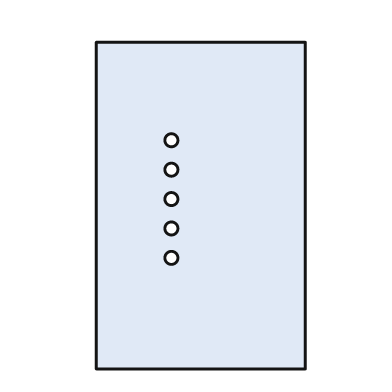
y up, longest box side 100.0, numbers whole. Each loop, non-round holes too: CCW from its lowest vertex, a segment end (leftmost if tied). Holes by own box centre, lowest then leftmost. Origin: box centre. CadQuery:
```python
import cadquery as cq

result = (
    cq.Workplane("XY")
    .moveTo(-32.0, -50.0)
    .lineTo(32.0, -50.0)
    .lineTo(32.0, 50.0)
    .lineTo(-32.0, 50.0)
    .close()
    .moveTo(-9.0, -16.0)
    .circle(2.0)
    .moveTo(-9.0, -7.0)
    .circle(2.0)
    .moveTo(-9.0, 2.0)
    .circle(2.0)
    .moveTo(-9.0, 11.0)
    .circle(2.0)
    .moveTo(-9.0, 20.0)
    .circle(2.0)
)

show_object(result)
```